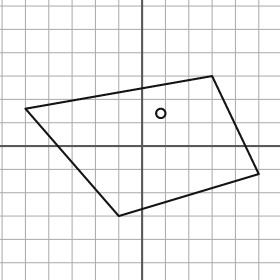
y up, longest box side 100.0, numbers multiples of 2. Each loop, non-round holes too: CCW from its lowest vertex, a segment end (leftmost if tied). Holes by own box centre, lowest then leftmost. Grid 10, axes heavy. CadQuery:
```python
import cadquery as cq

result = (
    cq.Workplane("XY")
    .moveTo(-10.0, -30.0)
    .lineTo(50.0, -12.0)
    .lineTo(30.0, 30.0)
    .lineTo(-50.0, 16.0)
    .close()
    .moveTo(8.0, 14.0)
    .circle(2.0)
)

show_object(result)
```